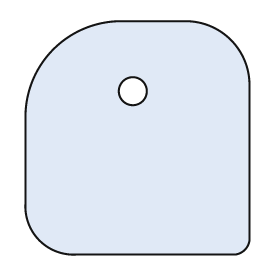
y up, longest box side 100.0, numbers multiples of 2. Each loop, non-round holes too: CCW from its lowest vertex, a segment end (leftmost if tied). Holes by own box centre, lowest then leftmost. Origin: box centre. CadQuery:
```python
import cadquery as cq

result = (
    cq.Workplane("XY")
    .moveTo(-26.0, -50.0)
    .lineTo(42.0, -50.0)
    .threePointArc((46.0, -48.0), (48.0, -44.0))
    .lineTo(48.0, 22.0)
    .threePointArc((40.0, 42.0), (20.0, 50.0))
    .lineTo(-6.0, 50.0)
    .threePointArc((-36.0, 38.0), (-48.0, 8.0))
    .lineTo(-48.0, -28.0)
    .threePointArc((-42.0, -44.0), (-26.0, -50.0))
    .close()
    .moveTo(-2.0, 20.0)
    .circle(6.0)
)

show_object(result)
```